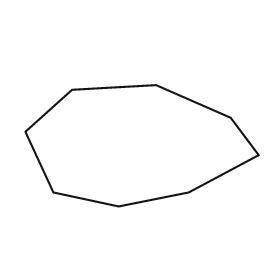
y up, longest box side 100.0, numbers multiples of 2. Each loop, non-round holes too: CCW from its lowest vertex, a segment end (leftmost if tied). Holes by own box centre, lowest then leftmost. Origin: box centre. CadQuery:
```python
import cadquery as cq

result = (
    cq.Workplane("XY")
    .moveTo(-10.0, -26.0)
    .lineTo(20.0, -20.0)
    .lineTo(50.0, -4.0)
    .lineTo(38.0, 12.0)
    .lineTo(6.0, 26.0)
    .lineTo(-30.0, 24.0)
    .lineTo(-50.0, 6.0)
    .lineTo(-38.0, -20.0)
    .close()
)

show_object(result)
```